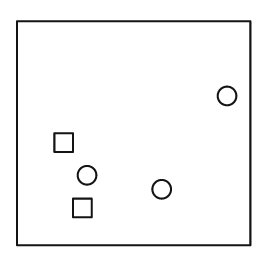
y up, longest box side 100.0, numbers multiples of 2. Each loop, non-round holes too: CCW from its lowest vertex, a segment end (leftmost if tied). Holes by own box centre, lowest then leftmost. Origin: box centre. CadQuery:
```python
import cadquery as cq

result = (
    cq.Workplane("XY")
    .moveTo(-50.0, -48.0)
    .lineTo(50.0, -48.0)
    .lineTo(50.0, 48.0)
    .lineTo(-50.0, 48.0)
    .close()
    .moveTo(-26.0, -36.0)
    .lineTo(-18.0, -36.0)
    .lineTo(-18.0, -28.0)
    .lineTo(-26.0, -28.0)
    .close()
    .moveTo(12.0, -24.0)
    .circle(4.0)
    .moveTo(-20.0, -18.0)
    .circle(4.0)
    .moveTo(-34.0, -8.0)
    .lineTo(-26.0, -8.0)
    .lineTo(-26.0, 0.0)
    .lineTo(-34.0, 0.0)
    .close()
    .moveTo(40.0, 16.0)
    .circle(4.0)
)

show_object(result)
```